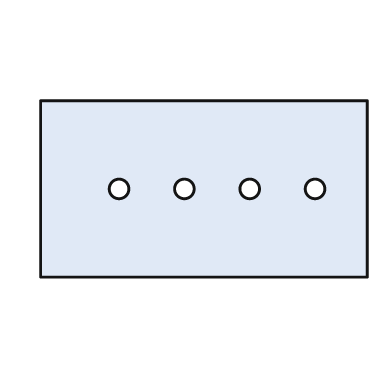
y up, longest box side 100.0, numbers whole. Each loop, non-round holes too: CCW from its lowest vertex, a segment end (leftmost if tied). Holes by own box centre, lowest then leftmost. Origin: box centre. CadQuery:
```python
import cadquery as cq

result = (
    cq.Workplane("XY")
    .moveTo(-50.0, -27.0)
    .lineTo(50.0, -27.0)
    .lineTo(50.0, 27.0)
    .lineTo(-50.0, 27.0)
    .close()
    .moveTo(-26.0, 0.0)
    .circle(3.0)
    .moveTo(-6.0, 0.0)
    .circle(3.0)
    .moveTo(14.0, 0.0)
    .circle(3.0)
    .moveTo(34.0, 0.0)
    .circle(3.0)
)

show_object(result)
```